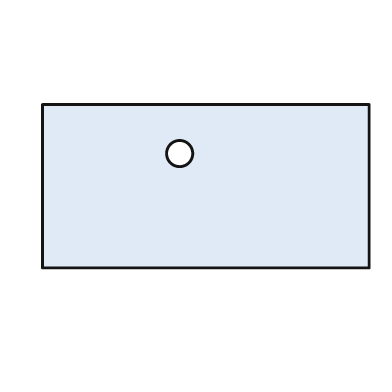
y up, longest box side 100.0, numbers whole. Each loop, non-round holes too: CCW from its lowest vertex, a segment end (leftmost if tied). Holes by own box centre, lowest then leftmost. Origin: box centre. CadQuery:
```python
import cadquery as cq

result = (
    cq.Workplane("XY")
    .moveTo(-50.0, -25.0)
    .lineTo(50.0, -25.0)
    .lineTo(50.0, 25.0)
    .lineTo(-50.0, 25.0)
    .close()
    .moveTo(-8.0, 10.0)
    .circle(4.0)
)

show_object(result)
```